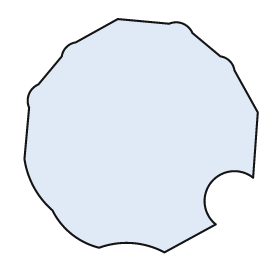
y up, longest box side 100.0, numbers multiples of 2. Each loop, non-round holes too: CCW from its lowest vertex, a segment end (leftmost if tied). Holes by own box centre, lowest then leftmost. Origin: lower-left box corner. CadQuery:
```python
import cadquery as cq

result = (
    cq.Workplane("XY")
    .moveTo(60.0, 0.0)
    .lineTo(82.0, 12.0)
    .threePointArc((80.0, 30.0), (98.0, 32.0))
    .lineTo(100.0, 60.0)
    .lineTo(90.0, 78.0)
    .threePointArc((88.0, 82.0), (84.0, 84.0))
    .lineTo(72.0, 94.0)
    .threePointArc((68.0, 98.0), (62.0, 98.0))
    .lineTo(40.0, 100.0)
    .lineTo(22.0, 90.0)
    .threePointArc((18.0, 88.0), (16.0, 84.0))
    .lineTo(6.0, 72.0)
    .threePointArc((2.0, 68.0), (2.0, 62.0))
    .lineTo(0.0, 40.0)
    .threePointArc((4.0, 28.0), (12.0, 18.0))
    .threePointArc((20.0, 8.0), (32.0, 2.0))
    .threePointArc((46.0, 4.0), (60.0, 0.0))
    .close()
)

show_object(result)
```